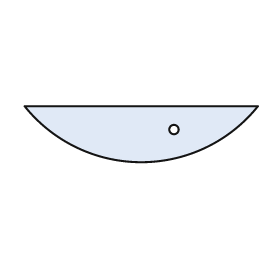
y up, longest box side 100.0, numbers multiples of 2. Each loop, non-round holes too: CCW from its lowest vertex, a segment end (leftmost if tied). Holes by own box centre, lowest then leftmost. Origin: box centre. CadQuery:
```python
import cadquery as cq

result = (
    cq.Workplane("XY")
    .moveTo(-50.0, 12.0)
    .threePointArc((0.0, -12.0), (50.0, 12.0))
    .close()
    .moveTo(14.0, 2.0)
    .circle(2.0)
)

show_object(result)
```